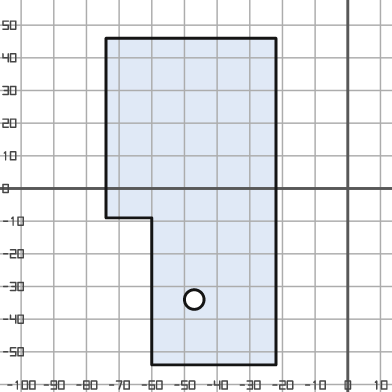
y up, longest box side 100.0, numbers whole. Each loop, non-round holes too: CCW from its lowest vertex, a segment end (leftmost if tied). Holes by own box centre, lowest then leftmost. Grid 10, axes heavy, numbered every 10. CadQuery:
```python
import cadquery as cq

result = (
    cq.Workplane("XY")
    .moveTo(-60.0, -54.0)
    .lineTo(-22.0, -54.0)
    .lineTo(-22.0, 46.0)
    .lineTo(-74.0, 46.0)
    .lineTo(-74.0, -9.0)
    .lineTo(-60.0, -9.0)
    .close()
    .moveTo(-47.0, -34.0)
    .circle(3.0)
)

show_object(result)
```